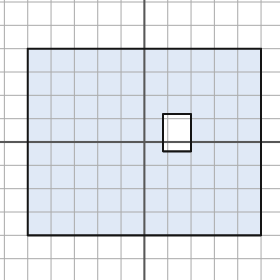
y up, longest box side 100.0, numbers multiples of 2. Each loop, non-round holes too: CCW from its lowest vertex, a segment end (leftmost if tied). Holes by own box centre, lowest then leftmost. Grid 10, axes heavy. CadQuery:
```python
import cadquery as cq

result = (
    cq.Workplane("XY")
    .moveTo(-50.0, -40.0)
    .lineTo(50.0, -40.0)
    .lineTo(50.0, 40.0)
    .lineTo(-50.0, 40.0)
    .close()
    .moveTo(8.0, -4.0)
    .lineTo(20.0, -4.0)
    .lineTo(20.0, 12.0)
    .lineTo(8.0, 12.0)
    .close()
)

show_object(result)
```